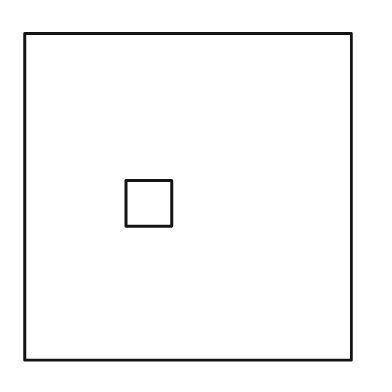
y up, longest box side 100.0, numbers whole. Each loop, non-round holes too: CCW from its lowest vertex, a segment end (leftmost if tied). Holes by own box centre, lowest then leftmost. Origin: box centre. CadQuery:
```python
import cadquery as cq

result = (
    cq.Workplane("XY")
    .moveTo(-50.0, -50.0)
    .lineTo(50.0, -50.0)
    .lineTo(50.0, 50.0)
    .lineTo(-50.0, 50.0)
    .close()
    .moveTo(-19.0, -9.0)
    .lineTo(-5.0, -9.0)
    .lineTo(-5.0, 5.0)
    .lineTo(-19.0, 5.0)
    .close()
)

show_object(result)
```